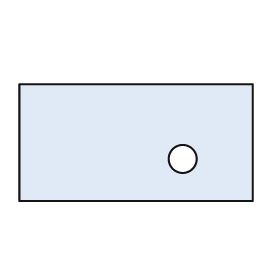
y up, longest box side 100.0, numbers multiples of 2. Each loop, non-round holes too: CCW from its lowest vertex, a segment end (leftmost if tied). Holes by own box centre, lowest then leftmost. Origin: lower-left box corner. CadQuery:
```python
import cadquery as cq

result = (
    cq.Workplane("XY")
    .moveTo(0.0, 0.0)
    .lineTo(100.0, 0.0)
    .lineTo(100.0, 50.0)
    .lineTo(0.0, 50.0)
    .close()
    .moveTo(70.0, 18.0)
    .circle(6.0)
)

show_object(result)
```